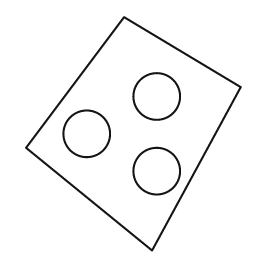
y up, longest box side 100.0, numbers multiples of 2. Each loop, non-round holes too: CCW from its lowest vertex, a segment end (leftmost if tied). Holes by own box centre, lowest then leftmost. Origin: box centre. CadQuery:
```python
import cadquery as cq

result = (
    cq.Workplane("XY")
    .moveTo(8.0, -50.0)
    .lineTo(46.0, 20.0)
    .lineTo(-4.0, 50.0)
    .lineTo(-46.0, -6.0)
    .close()
    .moveTo(10.0, -16.0)
    .circle(10.0)
    .moveTo(-20.0, 0.0)
    .circle(10.0)
    .moveTo(10.0, 16.0)
    .circle(10.0)
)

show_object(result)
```